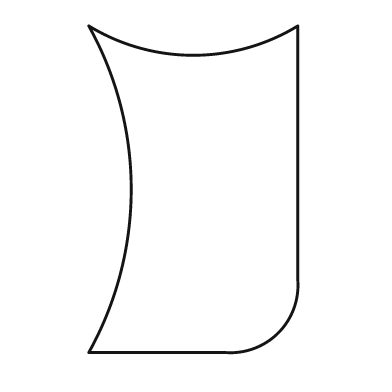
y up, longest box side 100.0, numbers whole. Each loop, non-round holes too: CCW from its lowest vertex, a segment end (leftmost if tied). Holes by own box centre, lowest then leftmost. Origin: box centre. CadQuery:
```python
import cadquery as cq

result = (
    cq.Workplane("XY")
    .moveTo(-32.0, -50.0)
    .lineTo(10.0, -50.0)
    .threePointArc((26.0, -44.0), (32.0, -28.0))
    .lineTo(32.0, 50.0)
    .threePointArc((0.0, 41.0), (-32.0, 50.0))
    .threePointArc((-19.0, 0.0), (-32.0, -50.0))
    .close()
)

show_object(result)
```